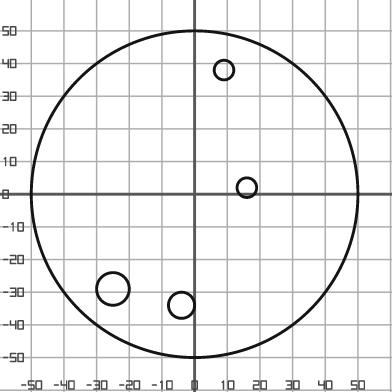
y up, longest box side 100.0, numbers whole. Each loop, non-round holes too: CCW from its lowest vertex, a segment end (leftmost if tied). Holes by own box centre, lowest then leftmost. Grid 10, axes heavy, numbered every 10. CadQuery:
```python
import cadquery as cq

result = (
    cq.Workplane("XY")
    .moveTo(0.0, 0.0)
    .circle(50.0)
    .moveTo(-4.0, -34.0)
    .circle(4.0)
    .moveTo(-25.0, -29.0)
    .circle(5.0)
    .moveTo(16.0, 2.0)
    .circle(3.0)
    .moveTo(9.0, 38.0)
    .circle(3.0)
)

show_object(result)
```